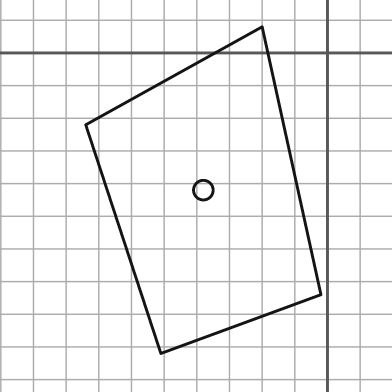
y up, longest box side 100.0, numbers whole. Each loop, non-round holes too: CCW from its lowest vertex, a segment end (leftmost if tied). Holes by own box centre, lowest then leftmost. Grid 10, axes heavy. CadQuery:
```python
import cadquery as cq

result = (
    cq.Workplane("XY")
    .moveTo(-51.0, -92.0)
    .lineTo(-2.0, -74.0)
    .lineTo(-20.0, 8.0)
    .lineTo(-74.0, -22.0)
    .close()
    .moveTo(-38.0, -42.0)
    .circle(3.0)
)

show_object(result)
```